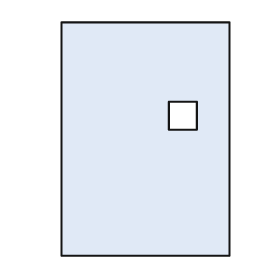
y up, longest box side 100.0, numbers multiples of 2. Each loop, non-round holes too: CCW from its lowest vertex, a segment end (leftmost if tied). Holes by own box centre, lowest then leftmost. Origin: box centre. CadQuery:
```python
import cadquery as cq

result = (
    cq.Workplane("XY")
    .moveTo(-36.0, -50.0)
    .lineTo(36.0, -50.0)
    .lineTo(36.0, 50.0)
    .lineTo(-36.0, 50.0)
    .close()
    .moveTo(10.0, 4.0)
    .lineTo(22.0, 4.0)
    .lineTo(22.0, 16.0)
    .lineTo(10.0, 16.0)
    .close()
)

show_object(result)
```